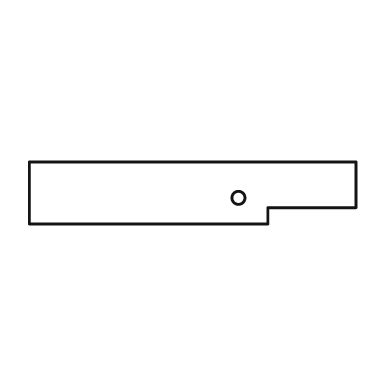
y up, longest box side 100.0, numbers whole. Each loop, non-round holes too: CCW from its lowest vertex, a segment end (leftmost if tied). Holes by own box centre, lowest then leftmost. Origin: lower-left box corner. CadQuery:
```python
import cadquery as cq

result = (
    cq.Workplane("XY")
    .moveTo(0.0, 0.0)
    .lineTo(73.0, 0.0)
    .lineTo(73.0, 5.0)
    .lineTo(100.0, 5.0)
    .lineTo(100.0, 19.0)
    .lineTo(0.0, 19.0)
    .close()
    .moveTo(64.0, 8.0)
    .circle(2.0)
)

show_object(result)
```